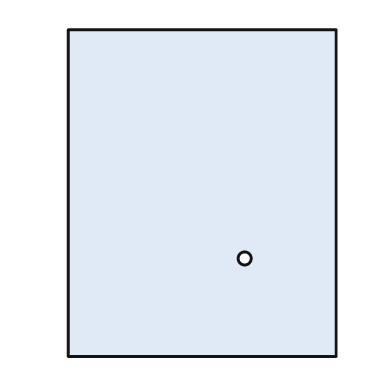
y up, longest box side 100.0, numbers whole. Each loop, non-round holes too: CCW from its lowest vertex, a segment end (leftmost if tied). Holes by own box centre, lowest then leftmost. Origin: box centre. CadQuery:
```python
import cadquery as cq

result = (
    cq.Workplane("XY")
    .moveTo(-41.0, -50.0)
    .lineTo(41.0, -50.0)
    .lineTo(41.0, 50.0)
    .lineTo(-41.0, 50.0)
    .close()
    .moveTo(13.0, -20.0)
    .circle(2.0)
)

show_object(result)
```